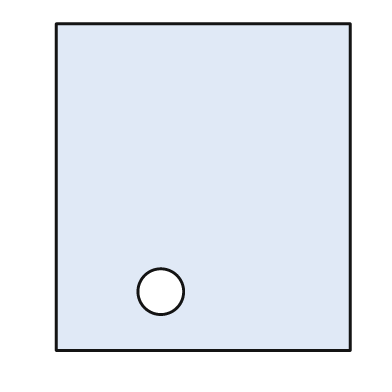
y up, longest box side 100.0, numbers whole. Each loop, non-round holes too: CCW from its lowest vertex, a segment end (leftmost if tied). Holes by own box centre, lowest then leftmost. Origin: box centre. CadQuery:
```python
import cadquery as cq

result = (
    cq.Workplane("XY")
    .moveTo(-45.0, -50.0)
    .lineTo(45.0, -50.0)
    .lineTo(45.0, 50.0)
    .lineTo(-45.0, 50.0)
    .close()
    .moveTo(-13.0, -32.0)
    .circle(7.0)
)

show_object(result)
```